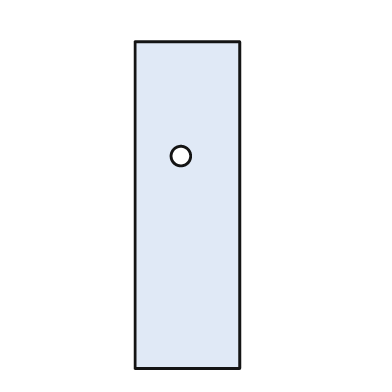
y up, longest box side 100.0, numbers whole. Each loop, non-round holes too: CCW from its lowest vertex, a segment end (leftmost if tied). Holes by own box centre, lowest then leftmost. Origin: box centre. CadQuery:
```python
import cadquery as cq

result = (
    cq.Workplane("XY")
    .moveTo(-16.0, -50.0)
    .lineTo(16.0, -50.0)
    .lineTo(16.0, 50.0)
    .lineTo(-16.0, 50.0)
    .close()
    .moveTo(-2.0, 15.0)
    .circle(3.0)
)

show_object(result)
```